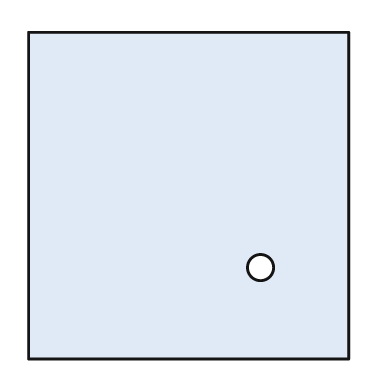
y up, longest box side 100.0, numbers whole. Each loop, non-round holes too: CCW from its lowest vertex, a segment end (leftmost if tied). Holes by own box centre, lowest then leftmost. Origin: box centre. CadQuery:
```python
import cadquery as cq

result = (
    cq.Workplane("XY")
    .moveTo(-49.0, -50.0)
    .lineTo(49.0, -50.0)
    .lineTo(49.0, 50.0)
    .lineTo(-49.0, 50.0)
    .close()
    .moveTo(22.0, -22.0)
    .circle(4.0)
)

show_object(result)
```